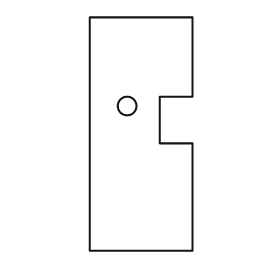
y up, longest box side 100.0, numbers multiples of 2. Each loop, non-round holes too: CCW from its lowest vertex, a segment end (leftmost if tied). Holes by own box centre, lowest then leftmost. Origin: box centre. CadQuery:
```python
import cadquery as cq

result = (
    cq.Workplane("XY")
    .moveTo(-22.0, -50.0)
    .lineTo(22.0, -50.0)
    .lineTo(22.0, -4.0)
    .lineTo(8.0, -4.0)
    .lineTo(8.0, 16.0)
    .lineTo(22.0, 16.0)
    .lineTo(22.0, 50.0)
    .lineTo(-22.0, 50.0)
    .close()
    .moveTo(-6.0, 12.0)
    .circle(4.0)
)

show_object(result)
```